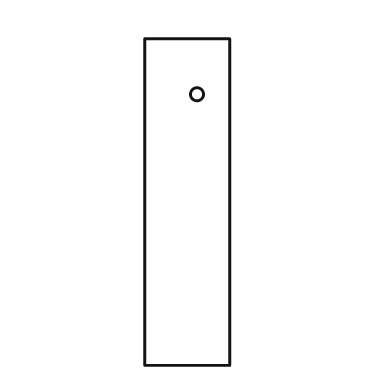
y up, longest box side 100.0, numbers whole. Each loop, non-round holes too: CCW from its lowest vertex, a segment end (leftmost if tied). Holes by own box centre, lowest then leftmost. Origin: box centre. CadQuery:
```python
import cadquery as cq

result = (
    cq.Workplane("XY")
    .moveTo(-13.0, -50.0)
    .lineTo(13.0, -50.0)
    .lineTo(13.0, 50.0)
    .lineTo(-13.0, 50.0)
    .close()
    .moveTo(3.0, 33.0)
    .circle(2.0)
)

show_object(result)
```